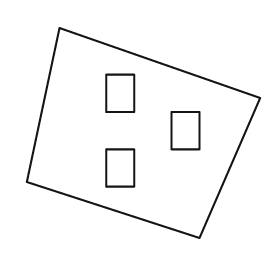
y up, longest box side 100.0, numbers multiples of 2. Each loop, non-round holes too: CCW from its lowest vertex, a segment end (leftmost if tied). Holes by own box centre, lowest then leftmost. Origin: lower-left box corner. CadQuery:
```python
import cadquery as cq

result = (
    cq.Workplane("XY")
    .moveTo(74.0, 0.0)
    .lineTo(100.0, 60.0)
    .lineTo(14.0, 90.0)
    .lineTo(0.0, 24.0)
    .close()
    .moveTo(34.0, 22.0)
    .lineTo(46.0, 22.0)
    .lineTo(46.0, 38.0)
    .lineTo(34.0, 38.0)
    .close()
    .moveTo(62.0, 38.0)
    .lineTo(74.0, 38.0)
    .lineTo(74.0, 54.0)
    .lineTo(62.0, 54.0)
    .close()
    .moveTo(34.0, 54.0)
    .lineTo(46.0, 54.0)
    .lineTo(46.0, 70.0)
    .lineTo(34.0, 70.0)
    .close()
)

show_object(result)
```